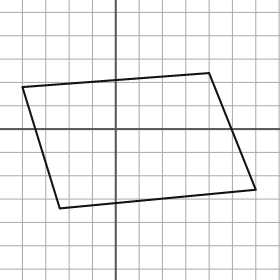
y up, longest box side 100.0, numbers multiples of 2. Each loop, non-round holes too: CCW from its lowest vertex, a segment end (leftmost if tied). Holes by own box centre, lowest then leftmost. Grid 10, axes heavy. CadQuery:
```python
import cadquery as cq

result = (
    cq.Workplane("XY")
    .moveTo(-24.0, -34.0)
    .lineTo(60.0, -26.0)
    .lineTo(40.0, 24.0)
    .lineTo(-40.0, 18.0)
    .close()
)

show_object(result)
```